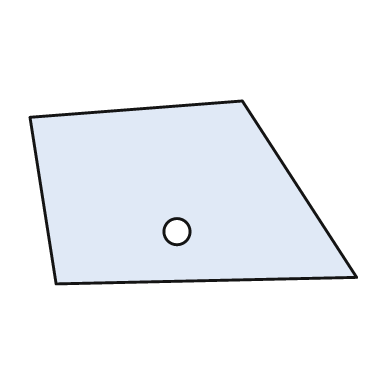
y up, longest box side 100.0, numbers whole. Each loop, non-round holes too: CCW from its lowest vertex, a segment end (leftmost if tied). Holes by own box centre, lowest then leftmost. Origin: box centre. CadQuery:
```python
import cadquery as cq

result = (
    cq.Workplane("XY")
    .moveTo(-42.0, -28.0)
    .lineTo(50.0, -26.0)
    .lineTo(15.0, 28.0)
    .lineTo(-50.0, 23.0)
    .close()
    .moveTo(-5.0, -12.0)
    .circle(4.0)
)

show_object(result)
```